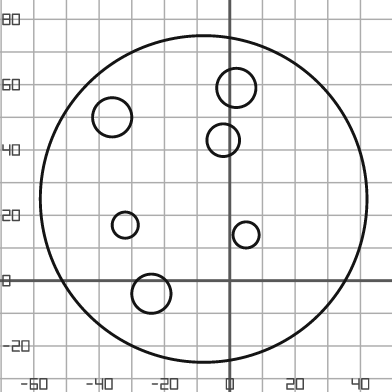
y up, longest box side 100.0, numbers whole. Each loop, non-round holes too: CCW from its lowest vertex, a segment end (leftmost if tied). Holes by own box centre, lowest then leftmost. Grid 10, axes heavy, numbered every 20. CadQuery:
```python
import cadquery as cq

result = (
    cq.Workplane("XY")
    .moveTo(-8.0, 25.0)
    .circle(50.0)
    .moveTo(-24.0, -4.0)
    .circle(6.0)
    .moveTo(5.0, 14.0)
    .circle(4.0)
    .moveTo(-32.0, 17.0)
    .circle(4.0)
    .moveTo(-2.0, 43.0)
    .circle(5.0)
    .moveTo(-36.0, 50.0)
    .circle(6.0)
    .moveTo(2.0, 59.0)
    .circle(6.0)
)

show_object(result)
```